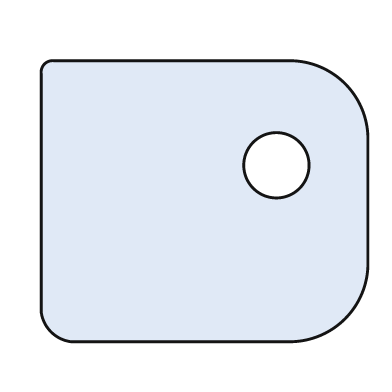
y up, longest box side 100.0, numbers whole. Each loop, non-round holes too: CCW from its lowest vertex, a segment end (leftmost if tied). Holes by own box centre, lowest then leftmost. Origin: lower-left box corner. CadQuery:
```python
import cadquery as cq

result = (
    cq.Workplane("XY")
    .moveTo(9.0, 0.0)
    .lineTo(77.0, 0.0)
    .threePointArc((93.0, 7.0), (100.0, 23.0))
    .lineTo(100.0, 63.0)
    .threePointArc((93.0, 79.0), (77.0, 86.0))
    .lineTo(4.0, 86.0)
    .threePointArc((1.0, 85.0), (0.0, 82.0))
    .lineTo(0.0, 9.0)
    .threePointArc((3.0, 3.0), (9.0, 0.0))
    .close()
    .moveTo(72.0, 54.0)
    .circle(10.0)
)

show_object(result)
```